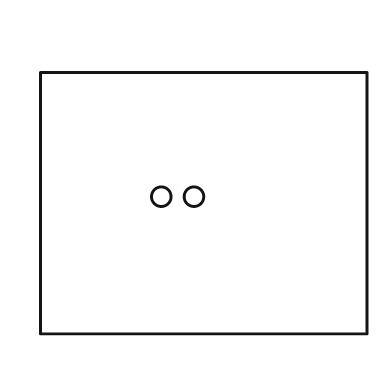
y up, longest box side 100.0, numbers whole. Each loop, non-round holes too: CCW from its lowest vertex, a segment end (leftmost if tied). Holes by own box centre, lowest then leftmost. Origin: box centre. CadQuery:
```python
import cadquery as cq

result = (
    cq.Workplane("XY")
    .moveTo(-50.0, -40.0)
    .lineTo(50.0, -40.0)
    .lineTo(50.0, 40.0)
    .lineTo(-50.0, 40.0)
    .close()
    .moveTo(-13.0, 2.0)
    .circle(3.0)
    .moveTo(-3.0, 2.0)
    .circle(3.0)
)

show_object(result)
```